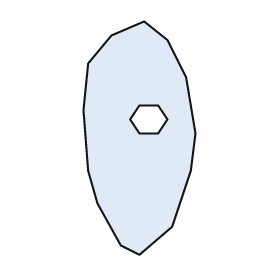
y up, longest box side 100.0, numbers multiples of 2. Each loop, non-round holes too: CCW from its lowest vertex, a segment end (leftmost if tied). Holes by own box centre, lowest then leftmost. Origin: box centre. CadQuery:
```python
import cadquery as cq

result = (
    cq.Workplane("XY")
    .moveTo(0.0, -50.0)
    .lineTo(14.0, -38.0)
    .lineTo(22.0, -14.0)
    .lineTo(24.0, 2.0)
    .lineTo(20.0, 26.0)
    .lineTo(12.0, 42.0)
    .lineTo(2.0, 50.0)
    .lineTo(-12.0, 44.0)
    .lineTo(-22.0, 32.0)
    .lineTo(-24.0, 12.0)
    .lineTo(-22.0, -14.0)
    .lineTo(-18.0, -28.0)
    .lineTo(-8.0, -46.0)
    .close()
    .moveTo(0.0, 2.0)
    .lineTo(8.0, 2.0)
    .lineTo(12.0, 8.0)
    .lineTo(8.0, 14.0)
    .lineTo(0.0, 14.0)
    .lineTo(-4.0, 8.0)
    .close()
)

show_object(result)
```